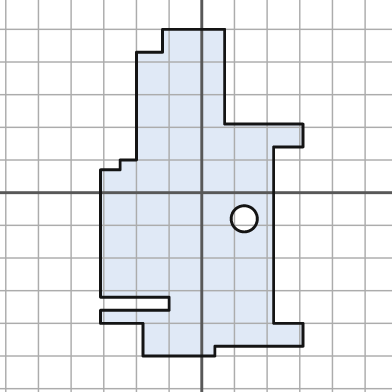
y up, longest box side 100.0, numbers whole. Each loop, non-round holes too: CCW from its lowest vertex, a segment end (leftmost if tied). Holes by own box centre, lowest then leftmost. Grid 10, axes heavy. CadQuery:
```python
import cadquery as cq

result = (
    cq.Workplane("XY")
    .moveTo(-18.0, -50.0)
    .lineTo(4.0, -50.0)
    .lineTo(4.0, -47.0)
    .lineTo(31.0, -47.0)
    .lineTo(31.0, -40.0)
    .lineTo(22.0, -40.0)
    .lineTo(22.0, 14.0)
    .lineTo(31.0, 14.0)
    .lineTo(31.0, 21.0)
    .lineTo(7.0, 21.0)
    .lineTo(7.0, 50.0)
    .lineTo(-12.0, 50.0)
    .lineTo(-12.0, 43.0)
    .lineTo(-20.0, 43.0)
    .lineTo(-20.0, 10.0)
    .lineTo(-25.0, 10.0)
    .lineTo(-25.0, 7.0)
    .lineTo(-31.0, 7.0)
    .lineTo(-31.0, -32.0)
    .lineTo(-10.0, -32.0)
    .lineTo(-10.0, -36.0)
    .lineTo(-31.0, -36.0)
    .lineTo(-31.0, -40.0)
    .lineTo(-18.0, -40.0)
    .close()
    .moveTo(13.0, -8.0)
    .circle(4.0)
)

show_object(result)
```